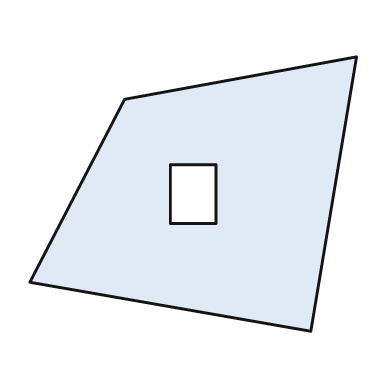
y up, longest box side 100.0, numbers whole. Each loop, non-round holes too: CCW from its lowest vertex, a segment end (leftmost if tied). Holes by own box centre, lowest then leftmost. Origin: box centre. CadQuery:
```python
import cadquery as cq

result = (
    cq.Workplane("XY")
    .moveTo(36.0, -42.0)
    .lineTo(50.0, 42.0)
    .lineTo(-21.0, 29.0)
    .lineTo(-50.0, -27.0)
    .close()
    .moveTo(-7.0, -9.0)
    .lineTo(7.0, -9.0)
    .lineTo(7.0, 9.0)
    .lineTo(-7.0, 9.0)
    .close()
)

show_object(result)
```